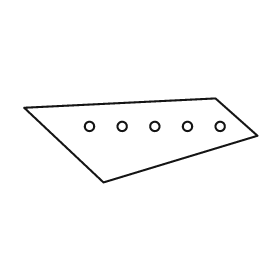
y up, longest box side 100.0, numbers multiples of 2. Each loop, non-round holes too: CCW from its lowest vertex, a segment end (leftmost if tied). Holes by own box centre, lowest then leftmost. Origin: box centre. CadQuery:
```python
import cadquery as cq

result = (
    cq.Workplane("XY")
    .moveTo(-16.0, -18.0)
    .lineTo(50.0, 2.0)
    .lineTo(32.0, 18.0)
    .lineTo(-50.0, 14.0)
    .close()
    .moveTo(-22.0, 6.0)
    .circle(2.0)
    .moveTo(-8.0, 6.0)
    .circle(2.0)
    .moveTo(6.0, 6.0)
    .circle(2.0)
    .moveTo(20.0, 6.0)
    .circle(2.0)
    .moveTo(34.0, 6.0)
    .circle(2.0)
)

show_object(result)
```